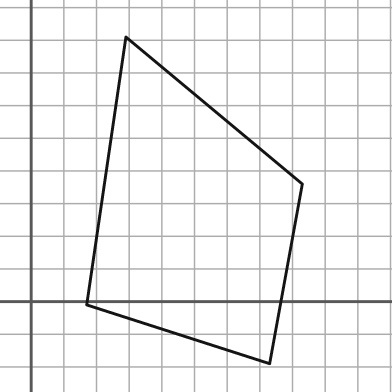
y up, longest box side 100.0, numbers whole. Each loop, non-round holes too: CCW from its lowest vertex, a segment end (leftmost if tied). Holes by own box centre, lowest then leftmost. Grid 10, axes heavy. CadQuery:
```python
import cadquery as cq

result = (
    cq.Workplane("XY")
    .moveTo(73.0, -19.0)
    .lineTo(83.0, 36.0)
    .lineTo(29.0, 81.0)
    .lineTo(17.0, -1.0)
    .close()
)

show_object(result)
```